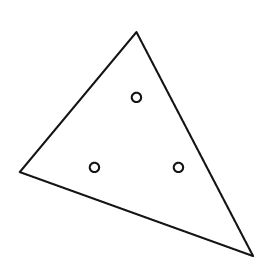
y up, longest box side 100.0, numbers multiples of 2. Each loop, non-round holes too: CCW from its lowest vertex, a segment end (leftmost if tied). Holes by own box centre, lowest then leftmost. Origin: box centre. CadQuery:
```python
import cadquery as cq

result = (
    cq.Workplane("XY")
    .moveTo(50.0, -48.0)
    .lineTo(0.0, 48.0)
    .lineTo(-50.0, -12.0)
    .close()
    .moveTo(-18.0, -10.0)
    .circle(2.0)
    .moveTo(18.0, -10.0)
    .circle(2.0)
    .moveTo(0.0, 20.0)
    .circle(2.0)
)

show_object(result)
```